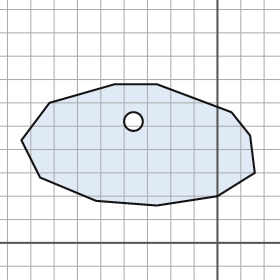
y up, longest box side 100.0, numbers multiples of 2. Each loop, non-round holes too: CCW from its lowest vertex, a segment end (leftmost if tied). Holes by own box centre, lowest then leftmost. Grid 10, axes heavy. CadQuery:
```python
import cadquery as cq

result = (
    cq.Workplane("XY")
    .moveTo(-26.0, 16.0)
    .lineTo(0.0, 20.0)
    .lineTo(16.0, 30.0)
    .lineTo(14.0, 46.0)
    .lineTo(6.0, 56.0)
    .lineTo(-26.0, 68.0)
    .lineTo(-44.0, 68.0)
    .lineTo(-72.0, 60.0)
    .lineTo(-84.0, 44.0)
    .lineTo(-76.0, 28.0)
    .lineTo(-52.0, 18.0)
    .close()
    .moveTo(-36.0, 52.0)
    .circle(4.0)
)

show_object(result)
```